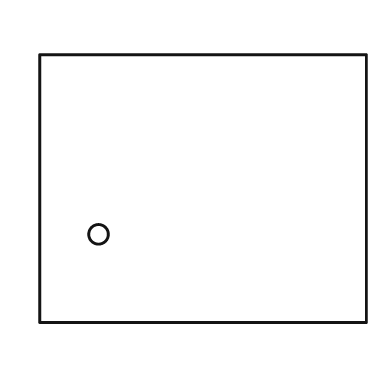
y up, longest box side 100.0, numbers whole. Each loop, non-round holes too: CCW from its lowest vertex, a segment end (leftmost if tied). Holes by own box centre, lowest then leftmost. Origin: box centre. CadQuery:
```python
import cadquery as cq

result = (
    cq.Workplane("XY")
    .moveTo(-50.0, -41.0)
    .lineTo(50.0, -41.0)
    .lineTo(50.0, 41.0)
    .lineTo(-50.0, 41.0)
    .close()
    .moveTo(-32.0, -14.0)
    .circle(3.0)
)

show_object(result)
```